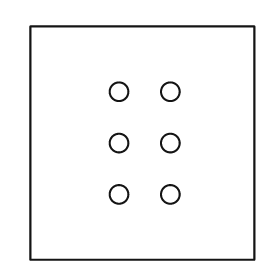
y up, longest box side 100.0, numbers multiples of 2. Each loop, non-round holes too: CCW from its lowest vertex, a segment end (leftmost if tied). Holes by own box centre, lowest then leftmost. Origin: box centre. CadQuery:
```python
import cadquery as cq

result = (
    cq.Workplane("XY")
    .moveTo(-48.0, -50.0)
    .lineTo(48.0, -50.0)
    .lineTo(48.0, 50.0)
    .lineTo(-48.0, 50.0)
    .close()
    .moveTo(-10.0, -22.0)
    .circle(4.0)
    .moveTo(12.0, -22.0)
    .circle(4.0)
    .moveTo(-10.0, 0.0)
    .circle(4.0)
    .moveTo(12.0, 0.0)
    .circle(4.0)
    .moveTo(-10.0, 22.0)
    .circle(4.0)
    .moveTo(12.0, 22.0)
    .circle(4.0)
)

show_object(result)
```